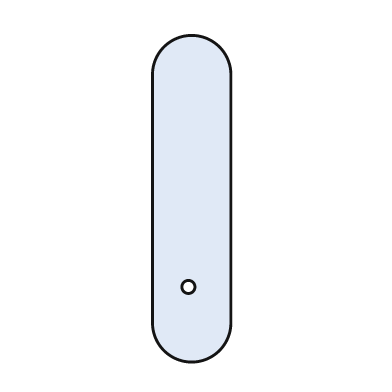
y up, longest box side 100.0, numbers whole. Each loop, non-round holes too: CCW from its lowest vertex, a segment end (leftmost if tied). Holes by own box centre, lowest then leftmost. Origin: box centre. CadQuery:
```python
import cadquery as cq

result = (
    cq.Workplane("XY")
    .moveTo(-12.0, -38.0)
    .threePointArc((0.0, -50.0), (12.0, -38.0))
    .lineTo(12.0, 38.0)
    .threePointArc((0.0, 50.0), (-12.0, 38.0))
    .close()
    .moveTo(-1.0, -27.0)
    .circle(2.0)
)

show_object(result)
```